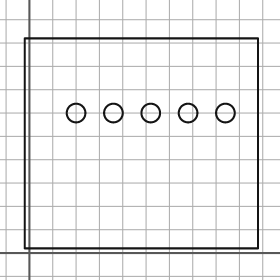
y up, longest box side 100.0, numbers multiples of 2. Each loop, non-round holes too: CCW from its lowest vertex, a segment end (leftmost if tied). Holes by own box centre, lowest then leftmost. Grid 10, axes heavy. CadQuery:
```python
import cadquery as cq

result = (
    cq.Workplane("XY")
    .moveTo(-2.0, 2.0)
    .lineTo(98.0, 2.0)
    .lineTo(98.0, 92.0)
    .lineTo(-2.0, 92.0)
    .close()
    .moveTo(20.0, 60.0)
    .circle(4.0)
    .moveTo(36.0, 60.0)
    .circle(4.0)
    .moveTo(52.0, 60.0)
    .circle(4.0)
    .moveTo(68.0, 60.0)
    .circle(4.0)
    .moveTo(84.0, 60.0)
    .circle(4.0)
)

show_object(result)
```